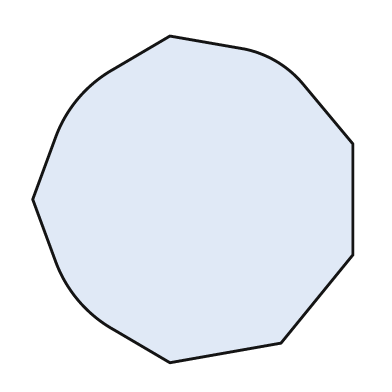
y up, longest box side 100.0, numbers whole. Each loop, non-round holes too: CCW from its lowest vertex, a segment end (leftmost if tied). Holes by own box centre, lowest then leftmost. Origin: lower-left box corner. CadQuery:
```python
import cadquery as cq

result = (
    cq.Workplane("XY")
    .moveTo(42.0, 0.0)
    .lineTo(76.0, 6.0)
    .lineTo(98.0, 33.0)
    .lineTo(98.0, 67.0)
    .lineTo(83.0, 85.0)
    .threePointArc((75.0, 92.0), (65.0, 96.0))
    .lineTo(42.0, 100.0)
    .lineTo(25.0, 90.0)
    .threePointArc((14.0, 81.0), (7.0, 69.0))
    .lineTo(0.0, 50.0)
    .lineTo(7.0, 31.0)
    .threePointArc((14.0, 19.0), (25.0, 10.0))
    .close()
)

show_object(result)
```